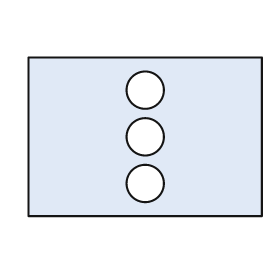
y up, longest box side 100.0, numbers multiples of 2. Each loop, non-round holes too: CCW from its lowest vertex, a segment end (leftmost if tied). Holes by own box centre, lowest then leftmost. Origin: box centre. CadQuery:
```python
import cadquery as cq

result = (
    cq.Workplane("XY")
    .moveTo(-50.0, -34.0)
    .lineTo(50.0, -34.0)
    .lineTo(50.0, 34.0)
    .lineTo(-50.0, 34.0)
    .close()
    .moveTo(0.0, -20.0)
    .circle(8.0)
    .moveTo(0.0, 0.0)
    .circle(8.0)
    .moveTo(0.0, 20.0)
    .circle(8.0)
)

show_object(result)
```